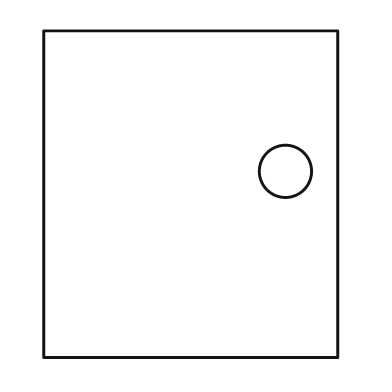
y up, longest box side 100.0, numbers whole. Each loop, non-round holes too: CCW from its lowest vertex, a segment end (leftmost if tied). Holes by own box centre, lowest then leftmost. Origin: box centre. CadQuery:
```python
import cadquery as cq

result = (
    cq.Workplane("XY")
    .moveTo(-45.0, -50.0)
    .lineTo(45.0, -50.0)
    .lineTo(45.0, 50.0)
    .lineTo(-45.0, 50.0)
    .close()
    .moveTo(29.0, 7.0)
    .circle(8.0)
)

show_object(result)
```